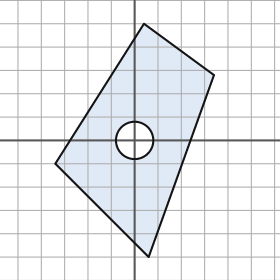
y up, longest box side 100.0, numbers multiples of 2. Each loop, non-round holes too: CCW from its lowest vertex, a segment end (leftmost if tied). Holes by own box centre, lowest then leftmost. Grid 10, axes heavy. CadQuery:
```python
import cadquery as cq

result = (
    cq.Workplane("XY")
    .moveTo(6.0, -50.0)
    .lineTo(34.0, 28.0)
    .lineTo(4.0, 50.0)
    .lineTo(-34.0, -10.0)
    .close()
    .moveTo(0.0, 0.0)
    .circle(8.0)
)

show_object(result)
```